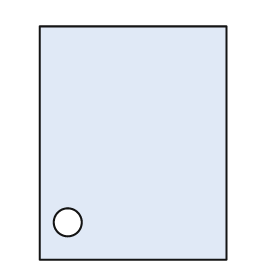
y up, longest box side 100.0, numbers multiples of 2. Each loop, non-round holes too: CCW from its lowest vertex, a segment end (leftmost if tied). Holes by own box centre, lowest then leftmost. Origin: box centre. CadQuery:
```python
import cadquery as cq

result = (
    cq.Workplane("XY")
    .moveTo(-40.0, -50.0)
    .lineTo(40.0, -50.0)
    .lineTo(40.0, 50.0)
    .lineTo(-40.0, 50.0)
    .close()
    .moveTo(-28.0, -34.0)
    .circle(6.0)
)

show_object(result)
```